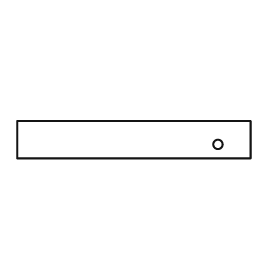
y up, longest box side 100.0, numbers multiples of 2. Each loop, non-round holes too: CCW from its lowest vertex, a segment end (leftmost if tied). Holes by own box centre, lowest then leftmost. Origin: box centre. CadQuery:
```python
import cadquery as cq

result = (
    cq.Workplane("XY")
    .moveTo(-50.0, -8.0)
    .lineTo(50.0, -8.0)
    .lineTo(50.0, 8.0)
    .lineTo(-50.0, 8.0)
    .close()
    .moveTo(36.0, -2.0)
    .circle(2.0)
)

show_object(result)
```